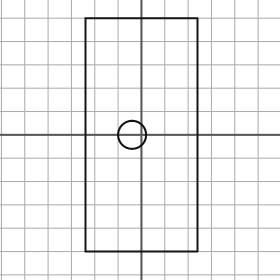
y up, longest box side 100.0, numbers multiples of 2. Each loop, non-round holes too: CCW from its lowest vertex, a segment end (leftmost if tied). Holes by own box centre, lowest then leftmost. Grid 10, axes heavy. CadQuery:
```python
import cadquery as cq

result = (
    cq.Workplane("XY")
    .moveTo(-24.0, -50.0)
    .lineTo(24.0, -50.0)
    .lineTo(24.0, 50.0)
    .lineTo(-24.0, 50.0)
    .close()
    .moveTo(-4.0, 0.0)
    .circle(6.0)
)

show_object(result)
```